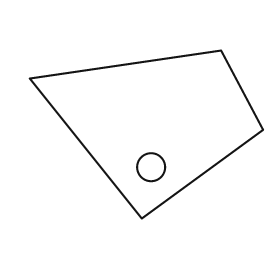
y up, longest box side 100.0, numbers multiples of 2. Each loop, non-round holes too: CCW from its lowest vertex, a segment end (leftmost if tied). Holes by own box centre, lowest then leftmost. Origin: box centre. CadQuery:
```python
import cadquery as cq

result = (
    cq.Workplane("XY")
    .moveTo(-2.0, -36.0)
    .lineTo(50.0, 2.0)
    .lineTo(32.0, 36.0)
    .lineTo(-50.0, 24.0)
    .close()
    .moveTo(2.0, -14.0)
    .circle(6.0)
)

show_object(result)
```